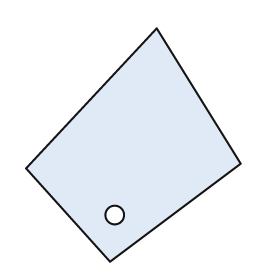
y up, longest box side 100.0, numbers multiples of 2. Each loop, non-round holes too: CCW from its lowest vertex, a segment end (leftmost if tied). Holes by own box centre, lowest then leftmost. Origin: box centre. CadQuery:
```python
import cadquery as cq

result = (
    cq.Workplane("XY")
    .moveTo(-10.0, -50.0)
    .lineTo(46.0, -8.0)
    .lineTo(10.0, 50.0)
    .lineTo(-46.0, -10.0)
    .close()
    .moveTo(-8.0, -30.0)
    .circle(4.0)
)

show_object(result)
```